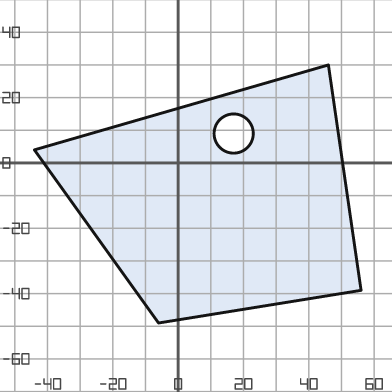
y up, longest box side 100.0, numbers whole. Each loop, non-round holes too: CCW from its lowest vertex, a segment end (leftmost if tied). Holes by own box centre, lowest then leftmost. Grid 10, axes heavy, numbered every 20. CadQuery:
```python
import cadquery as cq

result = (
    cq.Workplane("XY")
    .moveTo(-6.0, -49.0)
    .lineTo(56.0, -39.0)
    .lineTo(46.0, 30.0)
    .lineTo(-44.0, 4.0)
    .close()
    .moveTo(17.0, 9.0)
    .circle(6.0)
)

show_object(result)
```